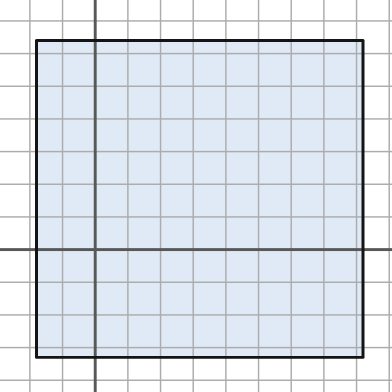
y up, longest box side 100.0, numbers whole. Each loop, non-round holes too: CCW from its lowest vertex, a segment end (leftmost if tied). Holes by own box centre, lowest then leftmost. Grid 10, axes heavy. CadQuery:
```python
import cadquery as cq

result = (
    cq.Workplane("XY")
    .moveTo(-18.0, -33.0)
    .lineTo(82.0, -33.0)
    .lineTo(82.0, 64.0)
    .lineTo(-18.0, 64.0)
    .close()
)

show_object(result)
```